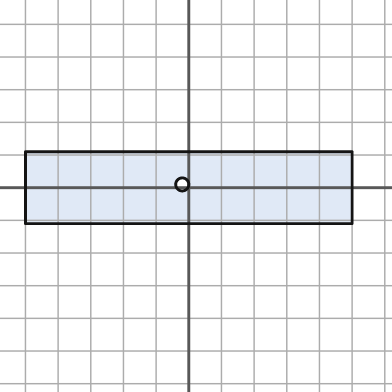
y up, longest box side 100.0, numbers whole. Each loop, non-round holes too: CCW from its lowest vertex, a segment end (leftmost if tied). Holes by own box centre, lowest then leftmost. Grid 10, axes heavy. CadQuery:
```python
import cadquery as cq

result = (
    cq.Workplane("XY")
    .moveTo(-50.0, -11.0)
    .lineTo(50.0, -11.0)
    .lineTo(50.0, 11.0)
    .lineTo(-50.0, 11.0)
    .close()
    .moveTo(-2.0, 1.0)
    .circle(2.0)
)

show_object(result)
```